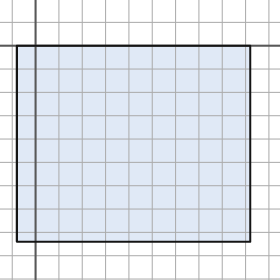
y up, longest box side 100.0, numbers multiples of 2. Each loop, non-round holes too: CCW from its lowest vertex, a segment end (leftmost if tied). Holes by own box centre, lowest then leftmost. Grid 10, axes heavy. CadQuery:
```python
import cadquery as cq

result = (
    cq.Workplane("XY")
    .moveTo(-8.0, -84.0)
    .lineTo(92.0, -84.0)
    .lineTo(92.0, 0.0)
    .lineTo(-8.0, 0.0)
    .close()
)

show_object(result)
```